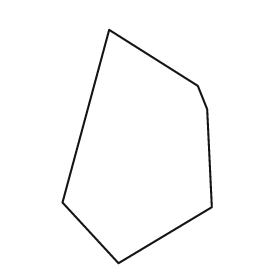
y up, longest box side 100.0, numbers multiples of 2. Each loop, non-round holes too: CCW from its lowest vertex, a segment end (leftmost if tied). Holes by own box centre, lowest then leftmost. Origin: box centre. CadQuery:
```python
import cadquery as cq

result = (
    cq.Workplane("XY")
    .moveTo(-8.0, -50.0)
    .lineTo(32.0, -26.0)
    .lineTo(30.0, 16.0)
    .lineTo(26.0, 26.0)
    .lineTo(-12.0, 50.0)
    .lineTo(-32.0, -24.0)
    .close()
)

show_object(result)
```